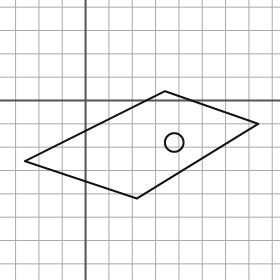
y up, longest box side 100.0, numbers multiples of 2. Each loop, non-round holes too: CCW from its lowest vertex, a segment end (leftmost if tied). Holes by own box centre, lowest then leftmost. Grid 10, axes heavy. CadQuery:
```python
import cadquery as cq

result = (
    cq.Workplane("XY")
    .moveTo(22.0, -42.0)
    .lineTo(74.0, -10.0)
    .lineTo(34.0, 4.0)
    .lineTo(-26.0, -26.0)
    .close()
    .moveTo(38.0, -18.0)
    .circle(4.0)
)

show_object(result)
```